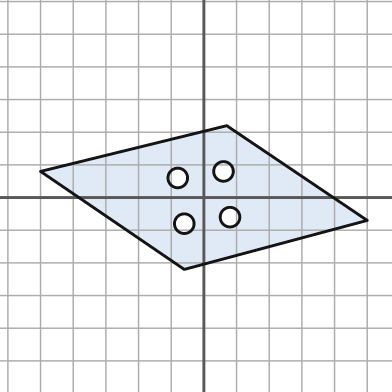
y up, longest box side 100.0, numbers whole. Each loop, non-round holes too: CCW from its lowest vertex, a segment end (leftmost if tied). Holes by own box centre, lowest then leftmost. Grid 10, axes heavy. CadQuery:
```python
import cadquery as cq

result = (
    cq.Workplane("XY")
    .moveTo(-6.0, -22.0)
    .lineTo(50.0, -7.0)
    .lineTo(7.0, 22.0)
    .lineTo(-50.0, 8.0)
    .close()
    .moveTo(-6.0, -8.0)
    .circle(3.0)
    .moveTo(8.0, -6.0)
    .circle(3.0)
    .moveTo(-8.0, 6.0)
    .circle(3.0)
    .moveTo(6.0, 8.0)
    .circle(3.0)
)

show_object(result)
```